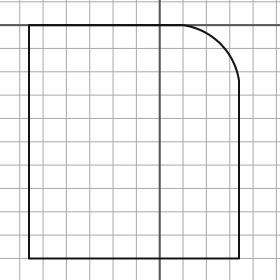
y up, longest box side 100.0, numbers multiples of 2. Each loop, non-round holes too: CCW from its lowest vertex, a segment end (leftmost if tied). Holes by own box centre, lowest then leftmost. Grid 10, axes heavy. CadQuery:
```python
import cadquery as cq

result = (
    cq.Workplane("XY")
    .moveTo(-56.0, -100.0)
    .lineTo(34.0, -100.0)
    .lineTo(34.0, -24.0)
    .threePointArc((26.0, -8.0), (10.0, 0.0))
    .lineTo(-56.0, 0.0)
    .close()
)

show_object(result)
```